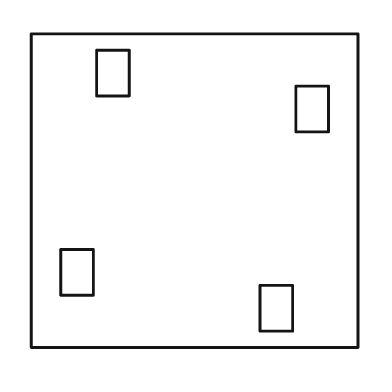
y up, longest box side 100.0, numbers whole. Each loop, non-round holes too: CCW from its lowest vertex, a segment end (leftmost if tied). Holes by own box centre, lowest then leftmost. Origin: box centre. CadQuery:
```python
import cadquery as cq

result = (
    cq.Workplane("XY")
    .moveTo(-50.0, -48.0)
    .lineTo(50.0, -48.0)
    .lineTo(50.0, 48.0)
    .lineTo(-50.0, 48.0)
    .close()
    .moveTo(20.0, -43.0)
    .lineTo(30.0, -43.0)
    .lineTo(30.0, -29.0)
    .lineTo(20.0, -29.0)
    .close()
    .moveTo(-41.0, -32.0)
    .lineTo(-31.0, -32.0)
    .lineTo(-31.0, -18.0)
    .lineTo(-41.0, -18.0)
    .close()
    .moveTo(31.0, 18.0)
    .lineTo(41.0, 18.0)
    .lineTo(41.0, 32.0)
    .lineTo(31.0, 32.0)
    .close()
    .moveTo(-30.0, 29.0)
    .lineTo(-20.0, 29.0)
    .lineTo(-20.0, 43.0)
    .lineTo(-30.0, 43.0)
    .close()
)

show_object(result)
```